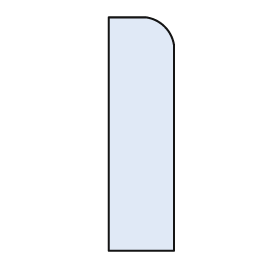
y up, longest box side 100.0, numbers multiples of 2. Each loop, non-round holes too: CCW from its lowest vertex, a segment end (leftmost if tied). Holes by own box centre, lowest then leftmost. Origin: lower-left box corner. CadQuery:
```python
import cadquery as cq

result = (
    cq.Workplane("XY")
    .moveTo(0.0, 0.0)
    .lineTo(28.0, 0.0)
    .lineTo(28.0, 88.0)
    .threePointArc((24.0, 96.0), (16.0, 100.0))
    .lineTo(0.0, 100.0)
    .close()
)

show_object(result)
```